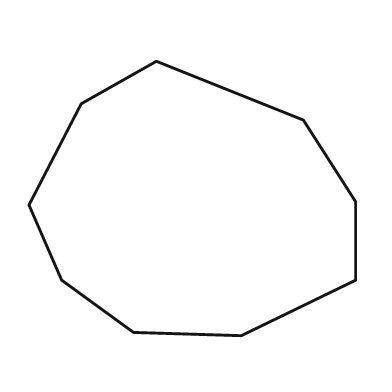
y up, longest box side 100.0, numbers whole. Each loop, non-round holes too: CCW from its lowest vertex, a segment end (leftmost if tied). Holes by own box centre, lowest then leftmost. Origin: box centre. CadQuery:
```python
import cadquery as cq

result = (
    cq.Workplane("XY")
    .moveTo(15.0, -42.0)
    .lineTo(50.0, -25.0)
    .lineTo(50.0, -1.0)
    .lineTo(34.0, 24.0)
    .lineTo(-11.0, 42.0)
    .lineTo(-34.0, 29.0)
    .lineTo(-50.0, -2.0)
    .lineTo(-40.0, -25.0)
    .lineTo(-18.0, -41.0)
    .close()
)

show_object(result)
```